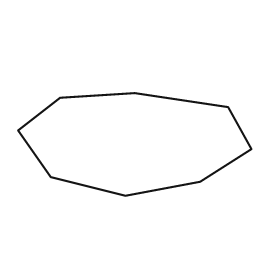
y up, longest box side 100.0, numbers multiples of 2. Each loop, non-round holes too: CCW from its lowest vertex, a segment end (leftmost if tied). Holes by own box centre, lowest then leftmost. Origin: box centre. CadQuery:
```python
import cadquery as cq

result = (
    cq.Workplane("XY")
    .moveTo(-4.0, -22.0)
    .lineTo(28.0, -16.0)
    .lineTo(50.0, -2.0)
    .lineTo(40.0, 16.0)
    .lineTo(0.0, 22.0)
    .lineTo(-32.0, 20.0)
    .lineTo(-50.0, 6.0)
    .lineTo(-36.0, -14.0)
    .close()
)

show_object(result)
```